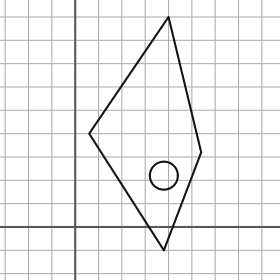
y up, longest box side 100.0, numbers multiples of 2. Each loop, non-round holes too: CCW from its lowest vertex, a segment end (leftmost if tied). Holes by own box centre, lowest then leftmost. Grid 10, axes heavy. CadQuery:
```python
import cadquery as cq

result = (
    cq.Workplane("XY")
    .moveTo(38.0, -10.0)
    .lineTo(54.0, 32.0)
    .lineTo(40.0, 90.0)
    .lineTo(6.0, 40.0)
    .close()
    .moveTo(38.0, 22.0)
    .circle(6.0)
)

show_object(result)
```